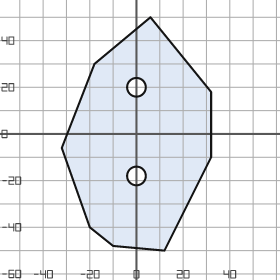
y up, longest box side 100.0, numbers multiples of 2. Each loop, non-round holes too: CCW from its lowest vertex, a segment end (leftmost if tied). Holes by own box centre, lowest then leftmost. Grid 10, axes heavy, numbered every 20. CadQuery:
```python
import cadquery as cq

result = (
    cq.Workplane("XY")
    .moveTo(12.0, -50.0)
    .lineTo(32.0, -10.0)
    .lineTo(32.0, 18.0)
    .lineTo(6.0, 50.0)
    .lineTo(-18.0, 30.0)
    .lineTo(-32.0, -6.0)
    .lineTo(-20.0, -40.0)
    .lineTo(-10.0, -48.0)
    .close()
    .moveTo(0.0, -18.0)
    .circle(4.0)
    .moveTo(0.0, 20.0)
    .circle(4.0)
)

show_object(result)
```